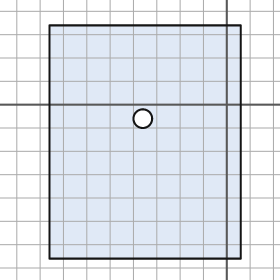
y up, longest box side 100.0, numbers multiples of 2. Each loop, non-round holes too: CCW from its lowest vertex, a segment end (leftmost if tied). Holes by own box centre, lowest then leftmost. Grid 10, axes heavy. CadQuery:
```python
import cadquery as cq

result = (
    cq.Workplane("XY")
    .moveTo(-76.0, -66.0)
    .lineTo(6.0, -66.0)
    .lineTo(6.0, 34.0)
    .lineTo(-76.0, 34.0)
    .close()
    .moveTo(-36.0, -6.0)
    .circle(4.0)
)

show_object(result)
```